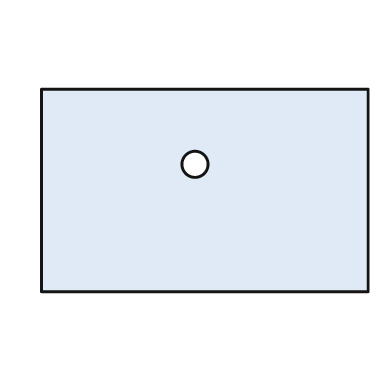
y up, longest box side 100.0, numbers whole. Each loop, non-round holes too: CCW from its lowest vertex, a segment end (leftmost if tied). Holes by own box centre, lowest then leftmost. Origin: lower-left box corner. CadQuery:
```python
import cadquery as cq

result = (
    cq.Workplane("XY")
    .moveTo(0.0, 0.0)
    .lineTo(100.0, 0.0)
    .lineTo(100.0, 62.0)
    .lineTo(0.0, 62.0)
    .close()
    .moveTo(47.0, 39.0)
    .circle(4.0)
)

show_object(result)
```